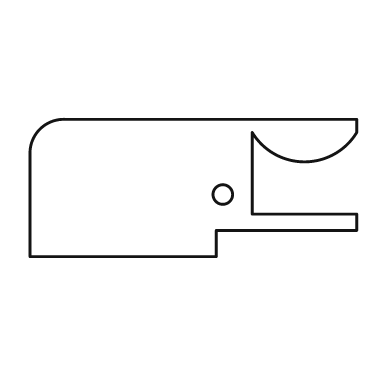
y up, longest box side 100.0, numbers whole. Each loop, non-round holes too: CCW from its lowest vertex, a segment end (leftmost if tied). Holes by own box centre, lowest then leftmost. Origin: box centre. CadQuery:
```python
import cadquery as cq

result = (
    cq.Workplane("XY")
    .moveTo(-50.0, -21.0)
    .lineTo(7.0, -21.0)
    .lineTo(7.0, -13.0)
    .lineTo(50.0, -13.0)
    .lineTo(50.0, -8.0)
    .lineTo(18.0, -8.0)
    .lineTo(18.0, 17.0)
    .threePointArc((34.0, 8.0), (50.0, 17.0))
    .lineTo(50.0, 21.0)
    .lineTo(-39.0, 21.0)
    .threePointArc((-47.0, 18.0), (-50.0, 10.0))
    .close()
    .moveTo(9.0, -2.0)
    .circle(3.0)
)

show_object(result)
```